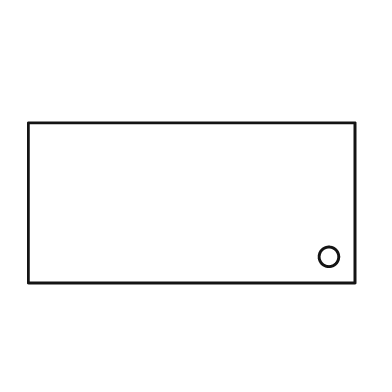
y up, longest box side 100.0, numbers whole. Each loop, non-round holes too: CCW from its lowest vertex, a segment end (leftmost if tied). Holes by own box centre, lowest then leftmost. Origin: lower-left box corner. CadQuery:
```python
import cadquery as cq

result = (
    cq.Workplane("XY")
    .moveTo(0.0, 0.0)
    .lineTo(100.0, 0.0)
    .lineTo(100.0, 49.0)
    .lineTo(0.0, 49.0)
    .close()
    .moveTo(92.0, 8.0)
    .circle(3.0)
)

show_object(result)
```